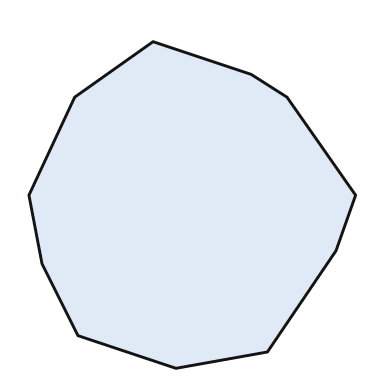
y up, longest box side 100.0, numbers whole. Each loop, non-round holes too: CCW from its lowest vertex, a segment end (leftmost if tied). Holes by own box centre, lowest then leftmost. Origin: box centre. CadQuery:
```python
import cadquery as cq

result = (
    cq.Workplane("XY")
    .moveTo(-5.0, -50.0)
    .lineTo(23.0, -45.0)
    .lineTo(44.0, -14.0)
    .lineTo(50.0, 3.0)
    .lineTo(29.0, 33.0)
    .lineTo(18.0, 40.0)
    .lineTo(-12.0, 50.0)
    .lineTo(-36.0, 33.0)
    .lineTo(-50.0, 3.0)
    .lineTo(-46.0, -18.0)
    .lineTo(-35.0, -40.0)
    .close()
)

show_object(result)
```